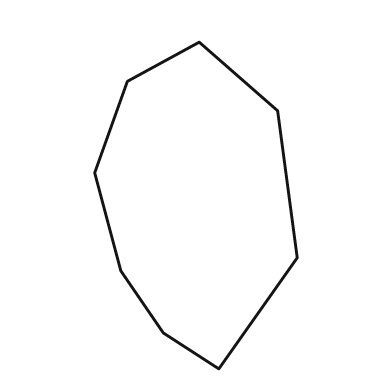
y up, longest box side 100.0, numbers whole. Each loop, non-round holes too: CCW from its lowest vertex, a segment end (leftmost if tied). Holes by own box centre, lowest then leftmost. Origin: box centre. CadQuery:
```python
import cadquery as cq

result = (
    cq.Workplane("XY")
    .moveTo(7.0, -50.0)
    .lineTo(31.0, -16.0)
    .lineTo(25.0, 29.0)
    .lineTo(1.0, 50.0)
    .lineTo(-21.0, 38.0)
    .lineTo(-31.0, 10.0)
    .lineTo(-23.0, -20.0)
    .lineTo(-10.0, -39.0)
    .close()
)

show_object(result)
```